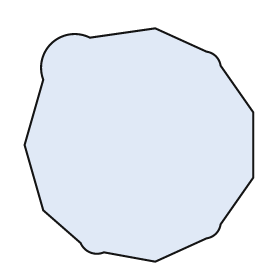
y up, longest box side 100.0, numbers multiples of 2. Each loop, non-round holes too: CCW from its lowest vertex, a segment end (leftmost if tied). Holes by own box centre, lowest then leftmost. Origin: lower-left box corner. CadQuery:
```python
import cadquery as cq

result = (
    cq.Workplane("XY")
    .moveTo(56.0, 0.0)
    .lineTo(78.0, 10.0)
    .threePointArc((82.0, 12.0), (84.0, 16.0))
    .lineTo(98.0, 36.0)
    .lineTo(98.0, 64.0)
    .lineTo(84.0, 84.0)
    .threePointArc((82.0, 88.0), (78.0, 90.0))
    .lineTo(56.0, 100.0)
    .lineTo(28.0, 96.0)
    .threePointArc((12.0, 94.0), (8.0, 78.0))
    .lineTo(0.0, 50.0)
    .lineTo(8.0, 22.0)
    .lineTo(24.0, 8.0)
    .threePointArc((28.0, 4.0), (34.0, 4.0))
    .close()
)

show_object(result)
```